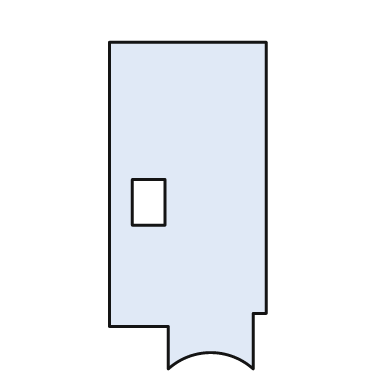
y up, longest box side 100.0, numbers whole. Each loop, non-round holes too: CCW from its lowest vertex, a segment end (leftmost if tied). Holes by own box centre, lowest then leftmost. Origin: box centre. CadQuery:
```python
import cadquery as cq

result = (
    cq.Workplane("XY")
    .moveTo(-6.0, -50.0)
    .threePointArc((7.0, -45.0), (20.0, -50.0))
    .lineTo(20.0, -33.0)
    .lineTo(24.0, -33.0)
    .lineTo(24.0, 50.0)
    .lineTo(-24.0, 50.0)
    .lineTo(-24.0, -37.0)
    .lineTo(-6.0, -37.0)
    .close()
    .moveTo(-17.0, -6.0)
    .lineTo(-7.0, -6.0)
    .lineTo(-7.0, 8.0)
    .lineTo(-17.0, 8.0)
    .close()
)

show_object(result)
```